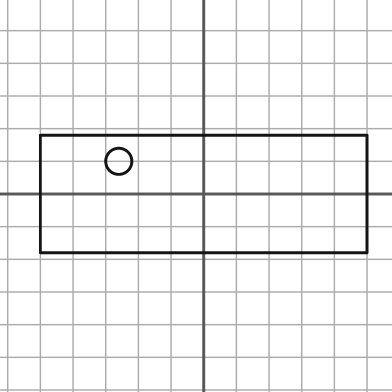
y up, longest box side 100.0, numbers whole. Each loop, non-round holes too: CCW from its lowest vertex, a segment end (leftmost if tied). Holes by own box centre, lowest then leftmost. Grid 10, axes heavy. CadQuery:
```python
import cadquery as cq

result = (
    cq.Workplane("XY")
    .moveTo(-50.0, -18.0)
    .lineTo(50.0, -18.0)
    .lineTo(50.0, 18.0)
    .lineTo(-50.0, 18.0)
    .close()
    .moveTo(-26.0, 10.0)
    .circle(4.0)
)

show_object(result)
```